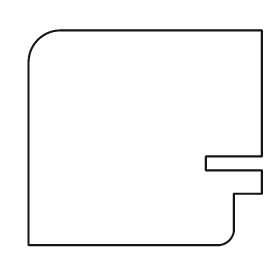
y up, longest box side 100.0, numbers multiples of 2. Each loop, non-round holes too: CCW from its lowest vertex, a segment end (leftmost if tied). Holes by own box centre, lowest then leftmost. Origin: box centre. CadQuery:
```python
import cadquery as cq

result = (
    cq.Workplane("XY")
    .moveTo(-50.0, -46.0)
    .lineTo(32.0, -46.0)
    .threePointArc((36.0, -44.0), (38.0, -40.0))
    .lineTo(38.0, -24.0)
    .lineTo(50.0, -24.0)
    .lineTo(50.0, -14.0)
    .lineTo(26.0, -14.0)
    .lineTo(26.0, -8.0)
    .lineTo(50.0, -8.0)
    .lineTo(50.0, 46.0)
    .lineTo(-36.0, 46.0)
    .threePointArc((-46.0, 42.0), (-50.0, 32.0))
    .close()
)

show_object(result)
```